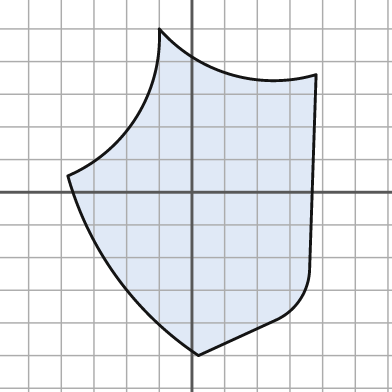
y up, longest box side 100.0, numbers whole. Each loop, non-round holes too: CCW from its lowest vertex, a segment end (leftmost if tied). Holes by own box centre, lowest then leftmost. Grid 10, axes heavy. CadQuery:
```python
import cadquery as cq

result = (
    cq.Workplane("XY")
    .moveTo(2.0, -50.0)
    .lineTo(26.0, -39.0)
    .threePointArc((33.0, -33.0), (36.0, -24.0))
    .lineTo(38.0, 36.0)
    .threePointArc((12.0, 36.0), (-10.0, 50.0))
    .threePointArc((-17.0, 23.0), (-38.0, 5.0))
    .threePointArc((-23.0, -26.0), (2.0, -50.0))
    .close()
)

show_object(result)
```